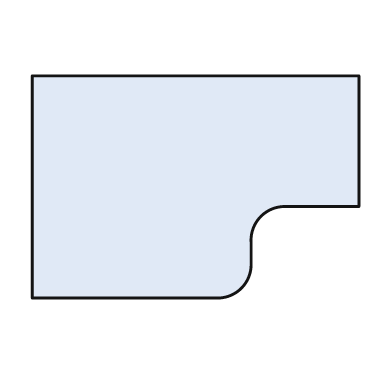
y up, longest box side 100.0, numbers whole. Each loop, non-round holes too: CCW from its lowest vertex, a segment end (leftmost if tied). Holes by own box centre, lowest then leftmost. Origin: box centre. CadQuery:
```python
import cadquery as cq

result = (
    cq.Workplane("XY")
    .moveTo(-50.0, -34.0)
    .lineTo(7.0, -34.0)
    .threePointArc((14.0, -31.0), (17.0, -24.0))
    .lineTo(17.0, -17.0)
    .threePointArc((20.0, -9.0), (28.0, -6.0))
    .lineTo(50.0, -6.0)
    .lineTo(50.0, 34.0)
    .lineTo(-50.0, 34.0)
    .close()
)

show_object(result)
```